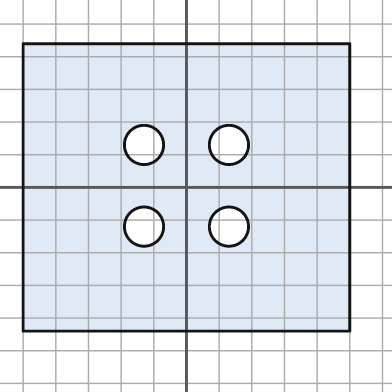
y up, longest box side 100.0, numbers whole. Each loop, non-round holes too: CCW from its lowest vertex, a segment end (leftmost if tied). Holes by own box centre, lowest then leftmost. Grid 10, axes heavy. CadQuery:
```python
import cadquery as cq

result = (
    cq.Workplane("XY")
    .moveTo(-50.0, -44.0)
    .lineTo(50.0, -44.0)
    .lineTo(50.0, 44.0)
    .lineTo(-50.0, 44.0)
    .close()
    .moveTo(-13.0, -12.0)
    .circle(6.0)
    .moveTo(13.0, -12.0)
    .circle(6.0)
    .moveTo(-13.0, 13.0)
    .circle(6.0)
    .moveTo(13.0, 13.0)
    .circle(6.0)
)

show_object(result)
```